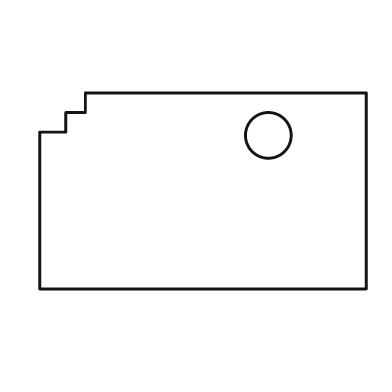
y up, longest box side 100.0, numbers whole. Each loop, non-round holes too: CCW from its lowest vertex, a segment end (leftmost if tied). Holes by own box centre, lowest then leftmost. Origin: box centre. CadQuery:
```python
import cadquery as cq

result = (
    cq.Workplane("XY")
    .moveTo(-50.0, -30.0)
    .lineTo(50.0, -30.0)
    .lineTo(50.0, 30.0)
    .lineTo(-36.0, 30.0)
    .lineTo(-36.0, 24.0)
    .lineTo(-42.0, 24.0)
    .lineTo(-42.0, 18.0)
    .lineTo(-50.0, 18.0)
    .close()
    .moveTo(20.0, 17.0)
    .circle(7.0)
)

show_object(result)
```